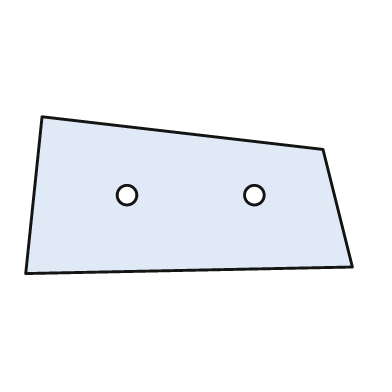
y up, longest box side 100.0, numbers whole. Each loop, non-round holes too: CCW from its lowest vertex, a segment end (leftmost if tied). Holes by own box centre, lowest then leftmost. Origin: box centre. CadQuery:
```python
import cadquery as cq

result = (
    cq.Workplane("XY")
    .moveTo(-50.0, -24.0)
    .lineTo(50.0, -22.0)
    .lineTo(41.0, 14.0)
    .lineTo(-45.0, 24.0)
    .close()
    .moveTo(-19.0, 0.0)
    .circle(3.0)
    .moveTo(20.0, 0.0)
    .circle(3.0)
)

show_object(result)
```